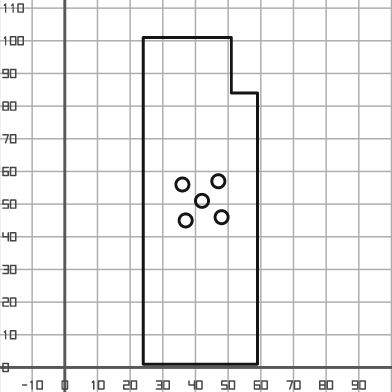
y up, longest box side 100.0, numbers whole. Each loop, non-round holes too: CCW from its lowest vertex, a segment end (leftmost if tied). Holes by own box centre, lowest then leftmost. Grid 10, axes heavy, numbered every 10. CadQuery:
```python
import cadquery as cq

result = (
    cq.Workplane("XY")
    .moveTo(24.0, 1.0)
    .lineTo(59.0, 1.0)
    .lineTo(59.0, 84.0)
    .lineTo(51.0, 84.0)
    .lineTo(51.0, 101.0)
    .lineTo(24.0, 101.0)
    .close()
    .moveTo(37.0, 45.0)
    .circle(2.0)
    .moveTo(48.0, 46.0)
    .circle(2.0)
    .moveTo(42.0, 51.0)
    .circle(2.0)
    .moveTo(36.0, 56.0)
    .circle(2.0)
    .moveTo(47.0, 57.0)
    .circle(2.0)
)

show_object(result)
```